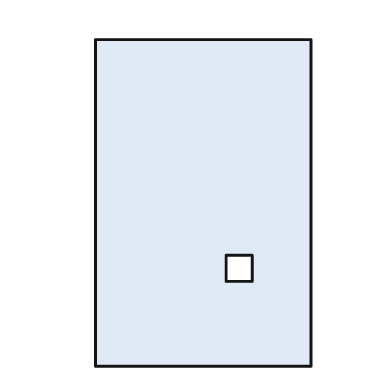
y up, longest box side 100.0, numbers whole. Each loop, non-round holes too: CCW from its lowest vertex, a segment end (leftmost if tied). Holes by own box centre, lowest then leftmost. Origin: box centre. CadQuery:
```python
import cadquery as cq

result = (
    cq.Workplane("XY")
    .moveTo(-33.0, -50.0)
    .lineTo(33.0, -50.0)
    .lineTo(33.0, 50.0)
    .lineTo(-33.0, 50.0)
    .close()
    .moveTo(7.0, -24.0)
    .lineTo(15.0, -24.0)
    .lineTo(15.0, -16.0)
    .lineTo(7.0, -16.0)
    .close()
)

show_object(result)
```